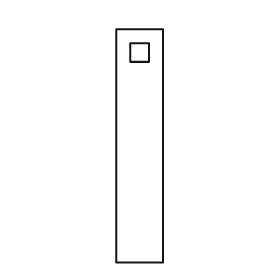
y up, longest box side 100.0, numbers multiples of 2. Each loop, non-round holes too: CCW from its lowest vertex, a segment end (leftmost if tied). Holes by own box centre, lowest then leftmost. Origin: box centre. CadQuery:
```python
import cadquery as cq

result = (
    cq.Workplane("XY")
    .moveTo(-10.0, -50.0)
    .lineTo(10.0, -50.0)
    .lineTo(10.0, 50.0)
    .lineTo(-10.0, 50.0)
    .close()
    .moveTo(-4.0, 36.0)
    .lineTo(4.0, 36.0)
    .lineTo(4.0, 44.0)
    .lineTo(-4.0, 44.0)
    .close()
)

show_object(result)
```